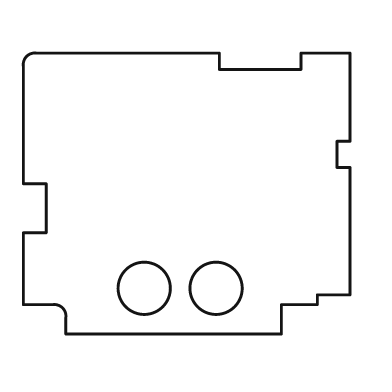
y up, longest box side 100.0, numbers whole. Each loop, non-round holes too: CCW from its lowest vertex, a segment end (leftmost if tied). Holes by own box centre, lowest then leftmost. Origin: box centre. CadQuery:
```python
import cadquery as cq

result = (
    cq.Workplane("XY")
    .moveTo(-37.0, -43.0)
    .lineTo(29.0, -43.0)
    .lineTo(29.0, -34.0)
    .lineTo(40.0, -34.0)
    .lineTo(40.0, -31.0)
    .lineTo(50.0, -31.0)
    .lineTo(50.0, 8.0)
    .lineTo(46.0, 8.0)
    .lineTo(46.0, 16.0)
    .lineTo(50.0, 16.0)
    .lineTo(50.0, 43.0)
    .lineTo(35.0, 43.0)
    .lineTo(35.0, 38.0)
    .lineTo(10.0, 38.0)
    .lineTo(10.0, 43.0)
    .lineTo(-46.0, 43.0)
    .threePointArc((-49.0, 42.0), (-50.0, 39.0))
    .lineTo(-50.0, 3.0)
    .lineTo(-43.0, 3.0)
    .lineTo(-43.0, -12.0)
    .lineTo(-50.0, -12.0)
    .lineTo(-50.0, -34.0)
    .lineTo(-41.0, -34.0)
    .threePointArc((-38.0, -35.0), (-37.0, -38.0))
    .close()
    .moveTo(-13.0, -29.0)
    .circle(8.0)
    .moveTo(9.0, -29.0)
    .circle(8.0)
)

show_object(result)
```